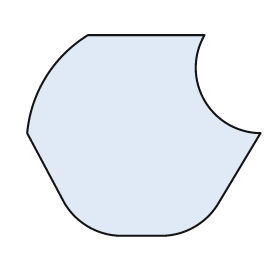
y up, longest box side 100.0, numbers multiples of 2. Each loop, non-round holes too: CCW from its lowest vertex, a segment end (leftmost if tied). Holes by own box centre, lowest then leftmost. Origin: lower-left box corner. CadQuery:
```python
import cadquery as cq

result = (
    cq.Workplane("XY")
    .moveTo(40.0, 0.0)
    .lineTo(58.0, 0.0)
    .threePointArc((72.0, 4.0), (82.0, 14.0))
    .lineTo(100.0, 44.0)
    .threePointArc((76.0, 58.0), (76.0, 86.0))
    .lineTo(26.0, 86.0)
    .threePointArc((8.0, 68.0), (0.0, 44.0))
    .lineTo(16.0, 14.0)
    .threePointArc((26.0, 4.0), (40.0, 0.0))
    .close()
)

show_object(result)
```